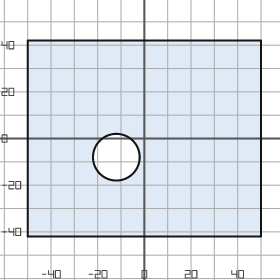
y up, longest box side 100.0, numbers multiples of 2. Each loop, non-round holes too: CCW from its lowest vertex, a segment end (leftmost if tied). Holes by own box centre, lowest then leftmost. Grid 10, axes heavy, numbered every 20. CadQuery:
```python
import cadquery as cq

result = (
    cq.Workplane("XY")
    .moveTo(-50.0, -42.0)
    .lineTo(50.0, -42.0)
    .lineTo(50.0, 42.0)
    .lineTo(-50.0, 42.0)
    .close()
    .moveTo(-12.0, -8.0)
    .circle(10.0)
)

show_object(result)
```